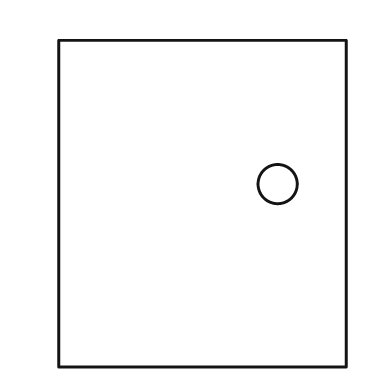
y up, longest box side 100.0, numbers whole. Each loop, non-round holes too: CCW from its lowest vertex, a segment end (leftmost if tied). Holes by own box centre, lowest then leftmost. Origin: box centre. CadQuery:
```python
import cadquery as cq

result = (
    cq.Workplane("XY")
    .moveTo(-44.0, -50.0)
    .lineTo(44.0, -50.0)
    .lineTo(44.0, 50.0)
    .lineTo(-44.0, 50.0)
    .close()
    .moveTo(23.0, 6.0)
    .circle(6.0)
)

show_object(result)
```